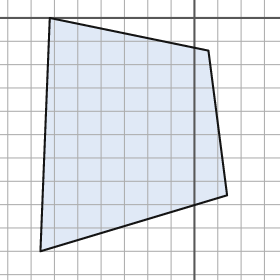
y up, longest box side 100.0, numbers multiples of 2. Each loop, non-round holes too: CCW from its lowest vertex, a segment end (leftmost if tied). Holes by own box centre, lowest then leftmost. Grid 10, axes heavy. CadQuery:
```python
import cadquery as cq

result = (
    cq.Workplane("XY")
    .moveTo(-66.0, -100.0)
    .lineTo(14.0, -76.0)
    .lineTo(6.0, -14.0)
    .lineTo(-62.0, 0.0)
    .close()
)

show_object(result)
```